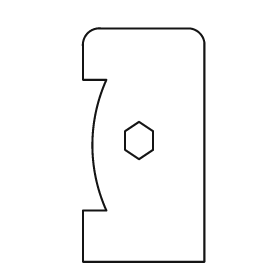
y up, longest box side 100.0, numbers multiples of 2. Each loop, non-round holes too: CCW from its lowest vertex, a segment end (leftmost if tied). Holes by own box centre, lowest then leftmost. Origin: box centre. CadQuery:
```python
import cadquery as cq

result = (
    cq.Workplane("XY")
    .moveTo(-26.0, -50.0)
    .lineTo(26.0, -50.0)
    .lineTo(26.0, 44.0)
    .threePointArc((24.0, 48.0), (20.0, 50.0))
    .lineTo(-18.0, 50.0)
    .threePointArc((-24.0, 48.0), (-26.0, 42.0))
    .lineTo(-26.0, 28.0)
    .lineTo(-16.0, 28.0)
    .threePointArc((-22.0, 0.0), (-16.0, -28.0))
    .lineTo(-26.0, -28.0)
    .close()
    .moveTo(-2.0, -6.0)
    .lineTo(4.0, -2.0)
    .lineTo(4.0, 6.0)
    .lineTo(-2.0, 10.0)
    .lineTo(-8.0, 6.0)
    .lineTo(-8.0, -2.0)
    .close()
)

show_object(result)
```